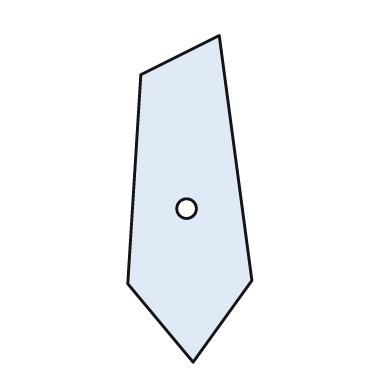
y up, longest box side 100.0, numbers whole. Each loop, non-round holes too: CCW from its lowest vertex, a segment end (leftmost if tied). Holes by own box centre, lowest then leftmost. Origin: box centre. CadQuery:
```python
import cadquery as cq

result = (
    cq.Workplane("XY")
    .moveTo(1.0, -50.0)
    .lineTo(19.0, -25.0)
    .lineTo(9.0, 50.0)
    .lineTo(-15.0, 38.0)
    .lineTo(-19.0, -26.0)
    .close()
    .moveTo(-1.0, -3.0)
    .circle(3.0)
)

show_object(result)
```